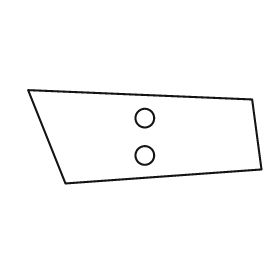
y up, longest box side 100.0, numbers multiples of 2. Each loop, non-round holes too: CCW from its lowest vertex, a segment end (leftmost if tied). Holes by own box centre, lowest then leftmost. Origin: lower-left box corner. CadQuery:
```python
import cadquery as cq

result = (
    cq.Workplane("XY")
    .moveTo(16.0, 0.0)
    .lineTo(100.0, 6.0)
    .lineTo(96.0, 36.0)
    .lineTo(0.0, 40.0)
    .close()
    .moveTo(50.0, 12.0)
    .circle(4.0)
    .moveTo(50.0, 28.0)
    .circle(4.0)
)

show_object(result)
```